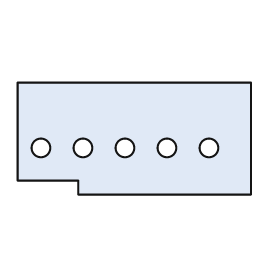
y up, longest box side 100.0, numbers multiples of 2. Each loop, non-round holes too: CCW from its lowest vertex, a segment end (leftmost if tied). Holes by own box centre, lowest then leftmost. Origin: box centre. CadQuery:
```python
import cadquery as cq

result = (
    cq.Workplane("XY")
    .moveTo(-24.0, -24.0)
    .lineTo(50.0, -24.0)
    .lineTo(50.0, 24.0)
    .lineTo(-50.0, 24.0)
    .lineTo(-50.0, -18.0)
    .lineTo(-24.0, -18.0)
    .close()
    .moveTo(-40.0, -4.0)
    .circle(4.0)
    .moveTo(-22.0, -4.0)
    .circle(4.0)
    .moveTo(-4.0, -4.0)
    .circle(4.0)
    .moveTo(14.0, -4.0)
    .circle(4.0)
    .moveTo(32.0, -4.0)
    .circle(4.0)
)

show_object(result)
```